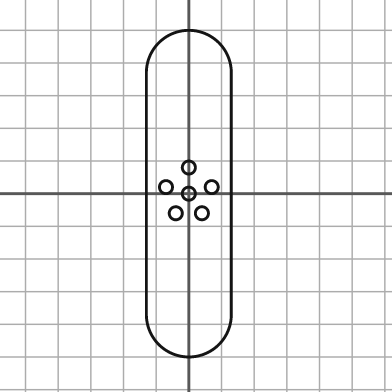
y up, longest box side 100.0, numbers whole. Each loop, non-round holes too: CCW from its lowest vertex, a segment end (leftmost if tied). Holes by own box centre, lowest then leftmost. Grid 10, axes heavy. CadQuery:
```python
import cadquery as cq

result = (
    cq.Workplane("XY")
    .moveTo(-13.0, -37.0)
    .threePointArc((0.0, -50.0), (13.0, -37.0))
    .lineTo(13.0, 37.0)
    .threePointArc((0.0, 50.0), (-13.0, 37.0))
    .close()
    .moveTo(-4.0, -6.0)
    .circle(2.0)
    .moveTo(4.0, -6.0)
    .circle(2.0)
    .moveTo(0.0, 0.0)
    .circle(2.0)
    .moveTo(-7.0, 2.0)
    .circle(2.0)
    .moveTo(7.0, 2.0)
    .circle(2.0)
    .moveTo(0.0, 8.0)
    .circle(2.0)
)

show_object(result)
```